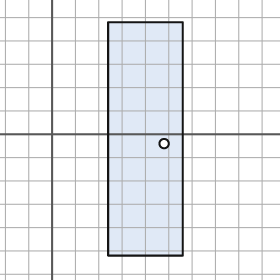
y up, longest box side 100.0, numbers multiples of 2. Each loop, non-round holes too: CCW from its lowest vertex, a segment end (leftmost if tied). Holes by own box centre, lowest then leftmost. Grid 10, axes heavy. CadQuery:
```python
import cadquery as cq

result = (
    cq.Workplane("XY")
    .moveTo(24.0, -52.0)
    .lineTo(56.0, -52.0)
    .lineTo(56.0, 48.0)
    .lineTo(24.0, 48.0)
    .close()
    .moveTo(48.0, -4.0)
    .circle(2.0)
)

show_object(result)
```